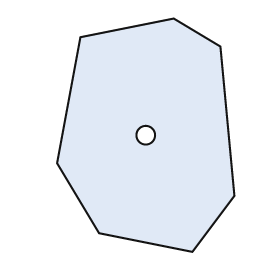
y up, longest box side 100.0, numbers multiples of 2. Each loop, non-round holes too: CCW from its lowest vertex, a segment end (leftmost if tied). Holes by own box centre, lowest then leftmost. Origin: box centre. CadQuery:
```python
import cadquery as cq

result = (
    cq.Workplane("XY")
    .moveTo(20.0, -50.0)
    .lineTo(38.0, -26.0)
    .lineTo(32.0, 38.0)
    .lineTo(12.0, 50.0)
    .lineTo(-28.0, 42.0)
    .lineTo(-38.0, -12.0)
    .lineTo(-20.0, -42.0)
    .close()
    .moveTo(0.0, 0.0)
    .circle(4.0)
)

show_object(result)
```